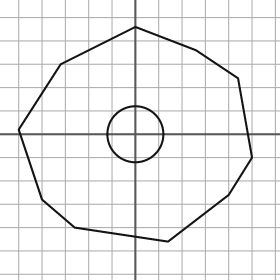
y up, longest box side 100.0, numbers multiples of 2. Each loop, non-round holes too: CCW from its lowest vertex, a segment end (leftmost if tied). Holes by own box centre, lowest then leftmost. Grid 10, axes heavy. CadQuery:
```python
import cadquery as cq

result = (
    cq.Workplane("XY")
    .moveTo(14.0, -46.0)
    .lineTo(40.0, -26.0)
    .lineTo(50.0, -10.0)
    .lineTo(44.0, 24.0)
    .lineTo(26.0, 36.0)
    .lineTo(0.0, 46.0)
    .lineTo(-32.0, 30.0)
    .lineTo(-50.0, 2.0)
    .lineTo(-40.0, -28.0)
    .lineTo(-26.0, -40.0)
    .close()
    .moveTo(0.0, 0.0)
    .circle(12.0)
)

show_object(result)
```